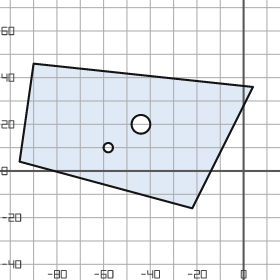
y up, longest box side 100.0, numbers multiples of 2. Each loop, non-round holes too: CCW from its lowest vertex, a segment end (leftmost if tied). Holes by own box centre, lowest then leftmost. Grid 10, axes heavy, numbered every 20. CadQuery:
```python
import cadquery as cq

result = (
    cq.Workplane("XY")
    .moveTo(-22.0, -16.0)
    .lineTo(4.0, 36.0)
    .lineTo(-90.0, 46.0)
    .lineTo(-96.0, 4.0)
    .close()
    .moveTo(-58.0, 10.0)
    .circle(2.0)
    .moveTo(-44.0, 20.0)
    .circle(4.0)
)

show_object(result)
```